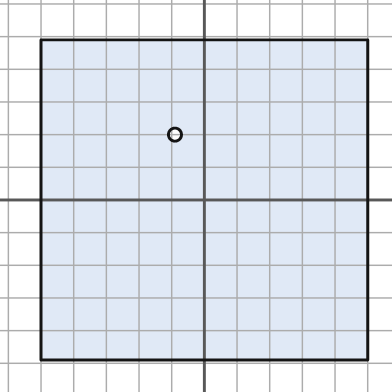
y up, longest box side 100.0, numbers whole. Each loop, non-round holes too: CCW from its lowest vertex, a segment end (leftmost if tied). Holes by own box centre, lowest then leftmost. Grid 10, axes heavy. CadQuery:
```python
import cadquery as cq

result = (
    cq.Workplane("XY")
    .moveTo(-50.0, -49.0)
    .lineTo(50.0, -49.0)
    .lineTo(50.0, 49.0)
    .lineTo(-50.0, 49.0)
    .close()
    .moveTo(-9.0, 20.0)
    .circle(2.0)
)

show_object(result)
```